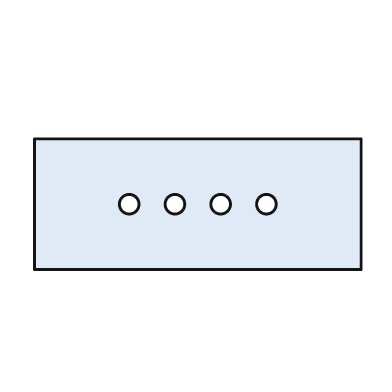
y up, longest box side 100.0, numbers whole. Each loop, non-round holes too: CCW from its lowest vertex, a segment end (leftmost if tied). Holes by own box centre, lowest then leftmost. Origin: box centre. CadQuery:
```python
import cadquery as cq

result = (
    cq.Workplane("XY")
    .moveTo(-50.0, -20.0)
    .lineTo(50.0, -20.0)
    .lineTo(50.0, 20.0)
    .lineTo(-50.0, 20.0)
    .close()
    .moveTo(-21.0, 0.0)
    .circle(3.0)
    .moveTo(-7.0, 0.0)
    .circle(3.0)
    .moveTo(7.0, 0.0)
    .circle(3.0)
    .moveTo(21.0, 0.0)
    .circle(3.0)
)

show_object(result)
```